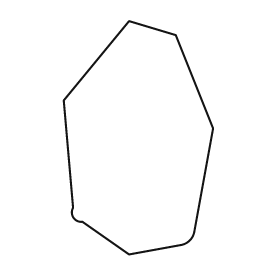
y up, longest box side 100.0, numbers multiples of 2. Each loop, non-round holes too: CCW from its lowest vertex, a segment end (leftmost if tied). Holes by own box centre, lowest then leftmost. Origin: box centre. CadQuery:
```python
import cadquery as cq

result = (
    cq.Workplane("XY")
    .moveTo(-4.0, -50.0)
    .lineTo(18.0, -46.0)
    .threePointArc((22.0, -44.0), (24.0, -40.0))
    .lineTo(32.0, 4.0)
    .lineTo(16.0, 44.0)
    .lineTo(-4.0, 50.0)
    .lineTo(-32.0, 16.0)
    .lineTo(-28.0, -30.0)
    .threePointArc((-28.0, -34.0), (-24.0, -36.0))
    .close()
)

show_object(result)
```